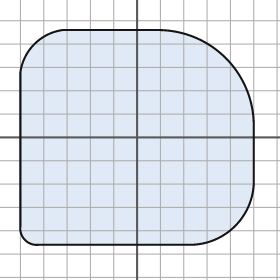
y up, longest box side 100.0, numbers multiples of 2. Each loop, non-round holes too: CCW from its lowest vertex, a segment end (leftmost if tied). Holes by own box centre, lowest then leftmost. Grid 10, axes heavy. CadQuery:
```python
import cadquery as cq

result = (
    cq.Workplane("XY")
    .moveTo(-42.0, -46.0)
    .lineTo(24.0, -46.0)
    .threePointArc((42.0, -38.0), (50.0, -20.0))
    .lineTo(50.0, 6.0)
    .threePointArc((38.0, 34.0), (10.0, 46.0))
    .lineTo(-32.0, 46.0)
    .threePointArc((-44.0, 40.0), (-50.0, 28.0))
    .lineTo(-50.0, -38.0)
    .threePointArc((-48.0, -44.0), (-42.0, -46.0))
    .close()
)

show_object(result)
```